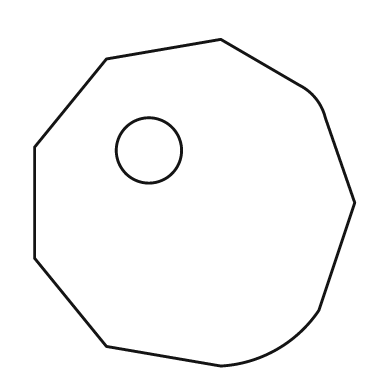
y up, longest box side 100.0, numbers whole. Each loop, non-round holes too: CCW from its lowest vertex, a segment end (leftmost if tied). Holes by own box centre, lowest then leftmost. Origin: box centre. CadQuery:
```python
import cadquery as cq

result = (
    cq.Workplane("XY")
    .moveTo(8.0, -50.0)
    .threePointArc((25.0, -45.0), (38.0, -33.0))
    .lineTo(49.0, 0.0)
    .lineTo(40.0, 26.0)
    .threePointArc((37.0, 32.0), (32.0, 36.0))
    .lineTo(8.0, 50.0)
    .lineTo(-27.0, 44.0)
    .lineTo(-49.0, 17.0)
    .lineTo(-49.0, -17.0)
    .lineTo(-27.0, -44.0)
    .close()
    .moveTo(-14.0, 16.0)
    .circle(10.0)
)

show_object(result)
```